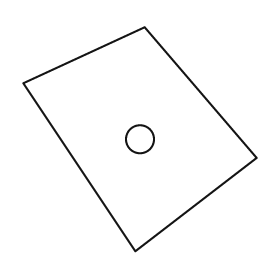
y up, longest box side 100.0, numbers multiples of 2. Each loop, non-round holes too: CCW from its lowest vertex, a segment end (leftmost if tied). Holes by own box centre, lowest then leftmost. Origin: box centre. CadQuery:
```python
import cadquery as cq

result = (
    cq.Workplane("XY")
    .moveTo(-2.0, -48.0)
    .lineTo(50.0, -8.0)
    .lineTo(2.0, 48.0)
    .lineTo(-50.0, 24.0)
    .close()
    .moveTo(0.0, 0.0)
    .circle(6.0)
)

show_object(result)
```